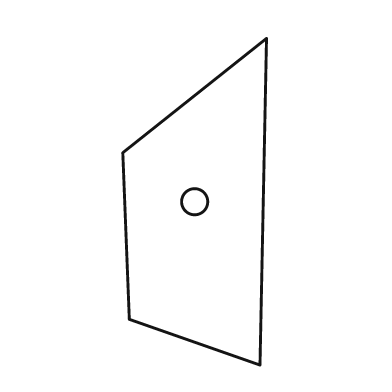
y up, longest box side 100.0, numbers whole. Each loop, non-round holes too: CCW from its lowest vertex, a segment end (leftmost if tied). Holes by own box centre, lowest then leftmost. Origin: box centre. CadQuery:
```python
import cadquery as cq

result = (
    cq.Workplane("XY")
    .moveTo(20.0, -50.0)
    .lineTo(22.0, 50.0)
    .lineTo(-22.0, 15.0)
    .lineTo(-20.0, -36.0)
    .close()
    .moveTo(0.0, 0.0)
    .circle(4.0)
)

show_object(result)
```